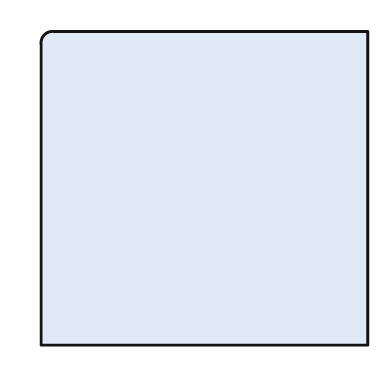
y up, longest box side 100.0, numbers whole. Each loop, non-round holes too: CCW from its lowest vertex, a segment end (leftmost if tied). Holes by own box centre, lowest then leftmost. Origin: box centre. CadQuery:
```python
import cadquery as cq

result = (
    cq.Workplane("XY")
    .moveTo(-50.0, -48.0)
    .lineTo(50.0, -48.0)
    .lineTo(50.0, 48.0)
    .lineTo(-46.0, 48.0)
    .threePointArc((-49.0, 47.0), (-50.0, 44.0))
    .close()
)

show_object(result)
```